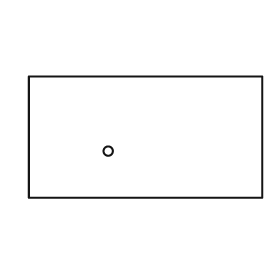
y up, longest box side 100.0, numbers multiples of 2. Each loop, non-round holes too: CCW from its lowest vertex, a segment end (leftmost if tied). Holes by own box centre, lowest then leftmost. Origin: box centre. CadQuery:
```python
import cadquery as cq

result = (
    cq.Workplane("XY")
    .moveTo(-50.0, -26.0)
    .lineTo(50.0, -26.0)
    .lineTo(50.0, 26.0)
    .lineTo(-50.0, 26.0)
    .close()
    .moveTo(-16.0, -6.0)
    .circle(2.0)
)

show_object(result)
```